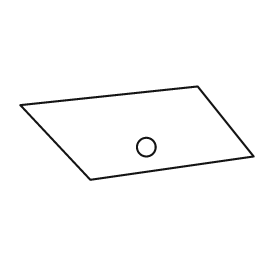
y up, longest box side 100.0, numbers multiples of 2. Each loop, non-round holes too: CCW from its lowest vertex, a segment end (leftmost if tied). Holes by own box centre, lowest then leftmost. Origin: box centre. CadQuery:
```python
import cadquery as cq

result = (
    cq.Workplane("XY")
    .moveTo(-20.0, -20.0)
    .lineTo(50.0, -10.0)
    .lineTo(26.0, 20.0)
    .lineTo(-50.0, 12.0)
    .close()
    .moveTo(4.0, -6.0)
    .circle(4.0)
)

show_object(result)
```